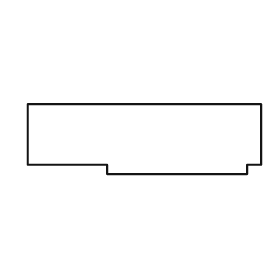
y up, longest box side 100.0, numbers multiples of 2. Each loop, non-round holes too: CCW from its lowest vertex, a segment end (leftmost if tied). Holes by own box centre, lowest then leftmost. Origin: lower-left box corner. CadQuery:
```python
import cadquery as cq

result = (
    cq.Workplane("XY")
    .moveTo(34.0, 0.0)
    .lineTo(94.0, 0.0)
    .lineTo(94.0, 4.0)
    .lineTo(100.0, 4.0)
    .lineTo(100.0, 30.0)
    .lineTo(0.0, 30.0)
    .lineTo(0.0, 4.0)
    .lineTo(34.0, 4.0)
    .close()
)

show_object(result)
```